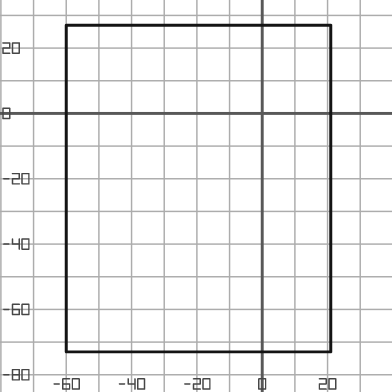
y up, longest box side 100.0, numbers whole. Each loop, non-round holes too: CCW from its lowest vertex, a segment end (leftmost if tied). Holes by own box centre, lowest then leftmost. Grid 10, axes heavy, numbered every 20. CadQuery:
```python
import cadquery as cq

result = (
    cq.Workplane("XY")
    .moveTo(-60.0, -73.0)
    .lineTo(21.0, -73.0)
    .lineTo(21.0, 27.0)
    .lineTo(-60.0, 27.0)
    .close()
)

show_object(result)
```